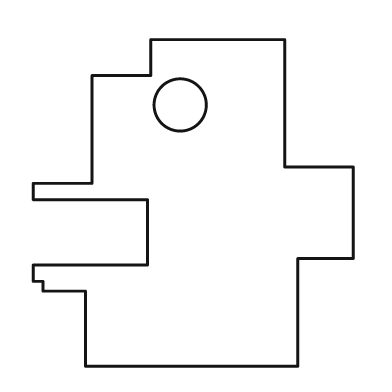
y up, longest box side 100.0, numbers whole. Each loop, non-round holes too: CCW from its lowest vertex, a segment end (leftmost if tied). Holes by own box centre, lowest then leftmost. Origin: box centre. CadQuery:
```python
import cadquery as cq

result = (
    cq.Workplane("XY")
    .moveTo(-33.0, -50.0)
    .lineTo(32.0, -50.0)
    .lineTo(32.0, -17.0)
    .lineTo(49.0, -17.0)
    .lineTo(49.0, 11.0)
    .lineTo(28.0, 11.0)
    .lineTo(28.0, 50.0)
    .lineTo(-13.0, 50.0)
    .lineTo(-13.0, 39.0)
    .lineTo(-31.0, 39.0)
    .lineTo(-31.0, 6.0)
    .lineTo(-49.0, 6.0)
    .lineTo(-49.0, 1.0)
    .lineTo(-14.0, 1.0)
    .lineTo(-14.0, -19.0)
    .lineTo(-49.0, -19.0)
    .lineTo(-49.0, -24.0)
    .lineTo(-46.0, -24.0)
    .lineTo(-46.0, -27.0)
    .lineTo(-33.0, -27.0)
    .close()
    .moveTo(-4.0, 30.0)
    .circle(8.0)
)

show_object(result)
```